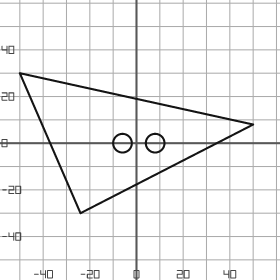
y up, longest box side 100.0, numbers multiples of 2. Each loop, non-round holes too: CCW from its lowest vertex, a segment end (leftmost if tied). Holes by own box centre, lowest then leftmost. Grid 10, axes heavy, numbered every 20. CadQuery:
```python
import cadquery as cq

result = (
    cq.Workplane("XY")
    .moveTo(-24.0, -30.0)
    .lineTo(50.0, 8.0)
    .lineTo(-50.0, 30.0)
    .close()
    .moveTo(-6.0, 0.0)
    .circle(4.0)
    .moveTo(8.0, 0.0)
    .circle(4.0)
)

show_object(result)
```